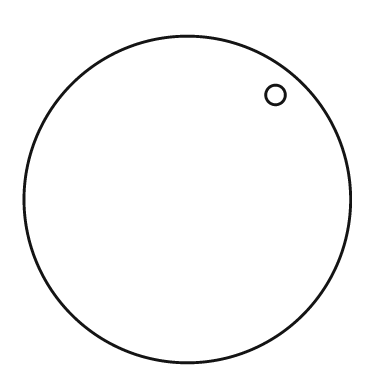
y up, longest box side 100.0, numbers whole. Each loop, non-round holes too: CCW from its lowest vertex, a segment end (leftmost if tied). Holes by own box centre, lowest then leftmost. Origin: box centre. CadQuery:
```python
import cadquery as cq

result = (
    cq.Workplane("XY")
    .moveTo(0.0, 0.0)
    .circle(50.0)
    .moveTo(27.0, 32.0)
    .circle(3.0)
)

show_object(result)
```